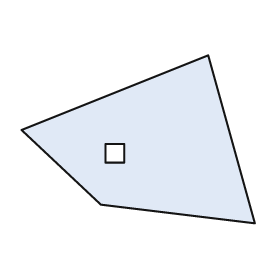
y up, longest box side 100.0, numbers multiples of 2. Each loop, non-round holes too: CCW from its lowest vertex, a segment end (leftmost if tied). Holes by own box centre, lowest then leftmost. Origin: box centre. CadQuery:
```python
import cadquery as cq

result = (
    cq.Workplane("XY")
    .moveTo(50.0, -36.0)
    .lineTo(30.0, 36.0)
    .lineTo(-50.0, 4.0)
    .lineTo(-16.0, -28.0)
    .close()
    .moveTo(-14.0, -10.0)
    .lineTo(-6.0, -10.0)
    .lineTo(-6.0, -2.0)
    .lineTo(-14.0, -2.0)
    .close()
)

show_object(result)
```